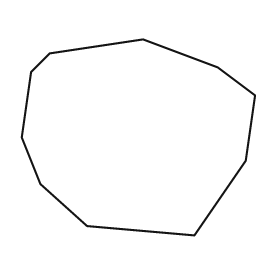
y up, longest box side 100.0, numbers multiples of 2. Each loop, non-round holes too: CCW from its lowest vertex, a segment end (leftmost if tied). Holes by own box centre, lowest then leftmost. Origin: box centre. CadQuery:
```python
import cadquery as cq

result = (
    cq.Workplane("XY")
    .moveTo(24.0, -42.0)
    .lineTo(46.0, -10.0)
    .lineTo(50.0, 18.0)
    .lineTo(34.0, 30.0)
    .lineTo(2.0, 42.0)
    .lineTo(-38.0, 36.0)
    .lineTo(-46.0, 28.0)
    .lineTo(-50.0, 0.0)
    .lineTo(-42.0, -20.0)
    .lineTo(-22.0, -38.0)
    .close()
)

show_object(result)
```